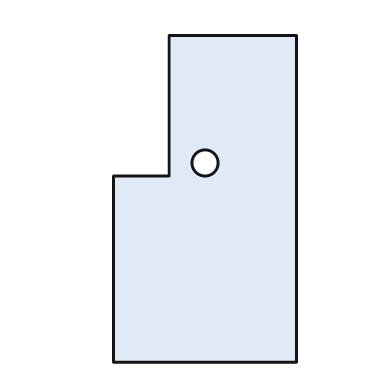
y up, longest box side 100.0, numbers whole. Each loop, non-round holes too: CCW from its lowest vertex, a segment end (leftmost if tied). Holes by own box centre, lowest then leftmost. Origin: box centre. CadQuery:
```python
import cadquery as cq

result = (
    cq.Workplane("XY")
    .moveTo(-28.0, -50.0)
    .lineTo(28.0, -50.0)
    .lineTo(28.0, 50.0)
    .lineTo(-11.0, 50.0)
    .lineTo(-11.0, 7.0)
    .lineTo(-28.0, 7.0)
    .close()
    .moveTo(0.0, 11.0)
    .circle(4.0)
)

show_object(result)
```